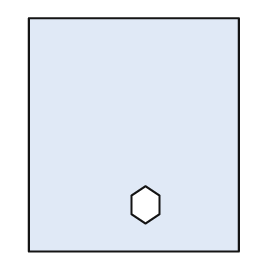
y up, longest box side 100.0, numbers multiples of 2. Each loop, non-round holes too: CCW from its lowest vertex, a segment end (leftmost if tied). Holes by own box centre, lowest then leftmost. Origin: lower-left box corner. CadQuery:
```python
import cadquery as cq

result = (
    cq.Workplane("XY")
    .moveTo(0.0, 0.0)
    .lineTo(90.0, 0.0)
    .lineTo(90.0, 100.0)
    .lineTo(0.0, 100.0)
    .close()
    .moveTo(50.0, 12.0)
    .lineTo(56.0, 16.0)
    .lineTo(56.0, 24.0)
    .lineTo(50.0, 28.0)
    .lineTo(44.0, 24.0)
    .lineTo(44.0, 16.0)
    .close()
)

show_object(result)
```